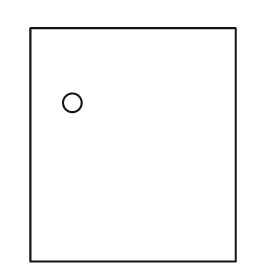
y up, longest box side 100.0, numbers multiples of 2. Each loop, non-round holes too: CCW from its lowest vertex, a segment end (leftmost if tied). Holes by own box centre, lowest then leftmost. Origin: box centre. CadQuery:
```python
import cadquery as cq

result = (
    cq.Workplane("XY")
    .moveTo(-44.0, -50.0)
    .lineTo(44.0, -50.0)
    .lineTo(44.0, 50.0)
    .lineTo(-44.0, 50.0)
    .close()
    .moveTo(-26.0, 18.0)
    .circle(4.0)
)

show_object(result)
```